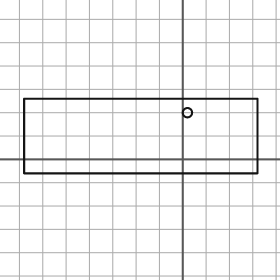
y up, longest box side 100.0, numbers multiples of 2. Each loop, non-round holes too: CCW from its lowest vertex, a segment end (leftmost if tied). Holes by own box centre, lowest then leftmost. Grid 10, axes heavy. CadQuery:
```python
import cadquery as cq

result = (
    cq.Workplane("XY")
    .moveTo(-68.0, -6.0)
    .lineTo(32.0, -6.0)
    .lineTo(32.0, 26.0)
    .lineTo(-68.0, 26.0)
    .close()
    .moveTo(2.0, 20.0)
    .circle(2.0)
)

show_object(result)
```